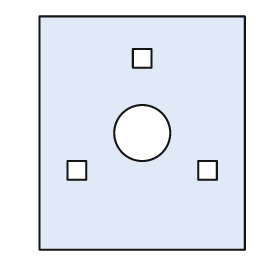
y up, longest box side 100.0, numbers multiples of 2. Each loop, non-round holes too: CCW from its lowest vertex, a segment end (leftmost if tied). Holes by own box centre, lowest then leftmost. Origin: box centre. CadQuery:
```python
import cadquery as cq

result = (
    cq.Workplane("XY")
    .moveTo(-44.0, -50.0)
    .lineTo(44.0, -50.0)
    .lineTo(44.0, 50.0)
    .lineTo(-44.0, 50.0)
    .close()
    .moveTo(-32.0, -20.0)
    .lineTo(-24.0, -20.0)
    .lineTo(-24.0, -12.0)
    .lineTo(-32.0, -12.0)
    .close()
    .moveTo(24.0, -20.0)
    .lineTo(32.0, -20.0)
    .lineTo(32.0, -12.0)
    .lineTo(24.0, -12.0)
    .close()
    .moveTo(0.0, 0.0)
    .circle(12.0)
    .moveTo(-4.0, 28.0)
    .lineTo(4.0, 28.0)
    .lineTo(4.0, 36.0)
    .lineTo(-4.0, 36.0)
    .close()
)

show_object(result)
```